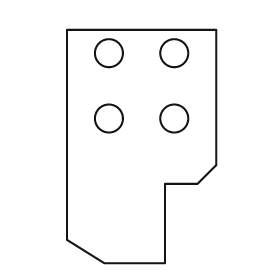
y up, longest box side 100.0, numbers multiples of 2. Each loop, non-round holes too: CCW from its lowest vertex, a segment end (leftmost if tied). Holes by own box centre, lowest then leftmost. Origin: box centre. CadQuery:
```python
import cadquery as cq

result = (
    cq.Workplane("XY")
    .moveTo(-16.0, -50.0)
    .lineTo(10.0, -50.0)
    .lineTo(10.0, -16.0)
    .lineTo(24.0, -16.0)
    .lineTo(32.0, -8.0)
    .lineTo(32.0, 50.0)
    .lineTo(-32.0, 50.0)
    .lineTo(-32.0, -40.0)
    .close()
    .moveTo(-14.0, 12.0)
    .circle(6.0)
    .moveTo(14.0, 12.0)
    .circle(6.0)
    .moveTo(-14.0, 40.0)
    .circle(6.0)
    .moveTo(14.0, 40.0)
    .circle(6.0)
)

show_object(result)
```